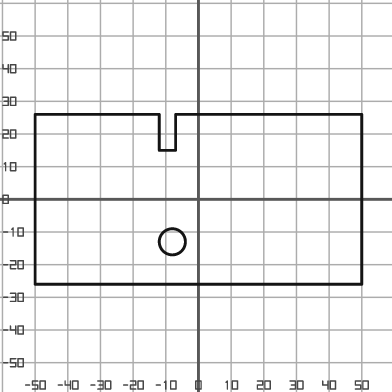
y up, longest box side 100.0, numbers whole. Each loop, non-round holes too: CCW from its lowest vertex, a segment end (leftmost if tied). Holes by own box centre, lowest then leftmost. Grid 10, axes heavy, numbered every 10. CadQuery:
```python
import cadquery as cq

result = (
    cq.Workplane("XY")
    .moveTo(-50.0, -26.0)
    .lineTo(50.0, -26.0)
    .lineTo(50.0, 26.0)
    .lineTo(-7.0, 26.0)
    .lineTo(-7.0, 15.0)
    .lineTo(-12.0, 15.0)
    .lineTo(-12.0, 26.0)
    .lineTo(-50.0, 26.0)
    .close()
    .moveTo(-8.0, -13.0)
    .circle(4.0)
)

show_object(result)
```